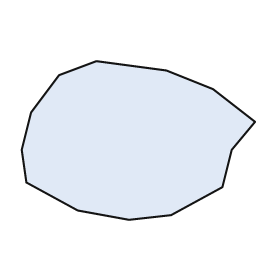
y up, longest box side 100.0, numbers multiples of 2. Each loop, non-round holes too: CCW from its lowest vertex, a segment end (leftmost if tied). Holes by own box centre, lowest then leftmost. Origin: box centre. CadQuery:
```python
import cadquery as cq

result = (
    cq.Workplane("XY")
    .moveTo(-4.0, -34.0)
    .lineTo(14.0, -32.0)
    .lineTo(36.0, -20.0)
    .lineTo(40.0, -4.0)
    .lineTo(50.0, 8.0)
    .lineTo(32.0, 22.0)
    .lineTo(12.0, 30.0)
    .lineTo(-18.0, 34.0)
    .lineTo(-34.0, 28.0)
    .lineTo(-46.0, 12.0)
    .lineTo(-50.0, -4.0)
    .lineTo(-48.0, -18.0)
    .lineTo(-26.0, -30.0)
    .close()
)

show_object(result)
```